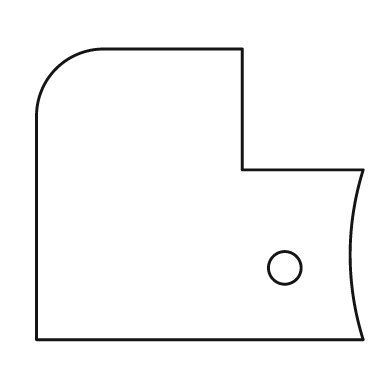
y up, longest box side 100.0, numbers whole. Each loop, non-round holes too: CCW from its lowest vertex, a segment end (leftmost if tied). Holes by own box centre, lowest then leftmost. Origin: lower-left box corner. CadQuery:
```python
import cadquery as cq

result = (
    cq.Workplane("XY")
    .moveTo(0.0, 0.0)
    .lineTo(100.0, 0.0)
    .threePointArc((96.0, 26.0), (100.0, 52.0))
    .lineTo(63.0, 52.0)
    .lineTo(63.0, 89.0)
    .lineTo(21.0, 89.0)
    .threePointArc((6.0, 83.0), (0.0, 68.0))
    .close()
    .moveTo(76.0, 22.0)
    .circle(5.0)
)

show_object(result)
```